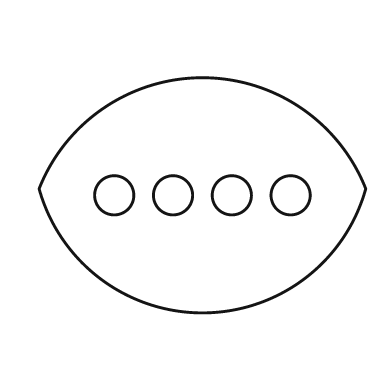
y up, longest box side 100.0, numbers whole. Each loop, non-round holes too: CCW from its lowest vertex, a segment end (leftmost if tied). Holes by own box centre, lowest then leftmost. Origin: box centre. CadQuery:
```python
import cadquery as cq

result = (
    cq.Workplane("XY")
    .moveTo(-50.0, 2.0)
    .threePointArc((0.0, -36.0), (50.0, 2.0))
    .threePointArc((0.0, 36.0), (-50.0, 2.0))
    .close()
    .moveTo(-27.0, 0.0)
    .circle(6.0)
    .moveTo(-9.0, 0.0)
    .circle(6.0)
    .moveTo(9.0, 0.0)
    .circle(6.0)
    .moveTo(27.0, 0.0)
    .circle(6.0)
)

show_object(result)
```